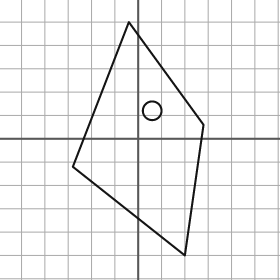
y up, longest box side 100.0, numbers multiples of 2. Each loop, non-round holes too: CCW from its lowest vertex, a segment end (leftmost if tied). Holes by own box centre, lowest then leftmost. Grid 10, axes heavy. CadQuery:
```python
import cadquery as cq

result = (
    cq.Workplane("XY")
    .moveTo(20.0, -50.0)
    .lineTo(28.0, 6.0)
    .lineTo(-4.0, 50.0)
    .lineTo(-28.0, -12.0)
    .close()
    .moveTo(6.0, 12.0)
    .circle(4.0)
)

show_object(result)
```